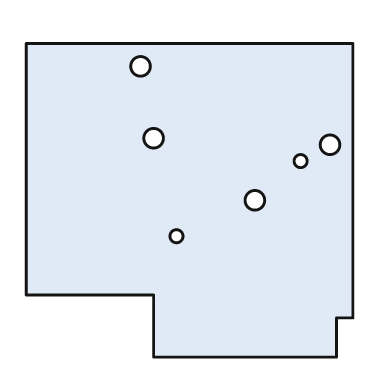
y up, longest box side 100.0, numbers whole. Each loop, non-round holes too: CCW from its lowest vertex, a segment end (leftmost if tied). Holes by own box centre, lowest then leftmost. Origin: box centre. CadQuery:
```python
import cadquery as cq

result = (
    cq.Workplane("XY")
    .moveTo(-11.0, -48.0)
    .lineTo(45.0, -48.0)
    .lineTo(45.0, -36.0)
    .lineTo(50.0, -36.0)
    .lineTo(50.0, 48.0)
    .lineTo(-50.0, 48.0)
    .lineTo(-50.0, -29.0)
    .lineTo(-11.0, -29.0)
    .close()
    .moveTo(-4.0, -11.0)
    .circle(2.0)
    .moveTo(20.0, 0.0)
    .circle(3.0)
    .moveTo(34.0, 12.0)
    .circle(2.0)
    .moveTo(43.0, 17.0)
    .circle(3.0)
    .moveTo(-11.0, 19.0)
    .circle(3.0)
    .moveTo(-15.0, 41.0)
    .circle(3.0)
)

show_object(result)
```